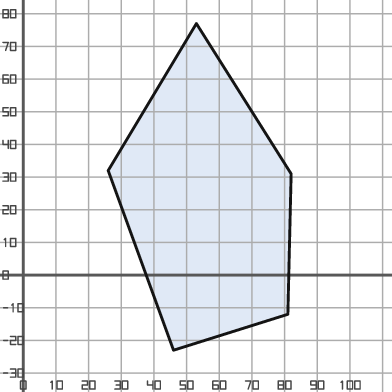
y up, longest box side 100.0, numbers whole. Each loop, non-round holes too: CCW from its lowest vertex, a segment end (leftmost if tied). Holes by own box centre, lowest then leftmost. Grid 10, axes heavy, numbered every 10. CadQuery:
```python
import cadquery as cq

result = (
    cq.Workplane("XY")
    .moveTo(46.0, -23.0)
    .lineTo(81.0, -12.0)
    .lineTo(82.0, 31.0)
    .lineTo(53.0, 77.0)
    .lineTo(26.0, 32.0)
    .close()
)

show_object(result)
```